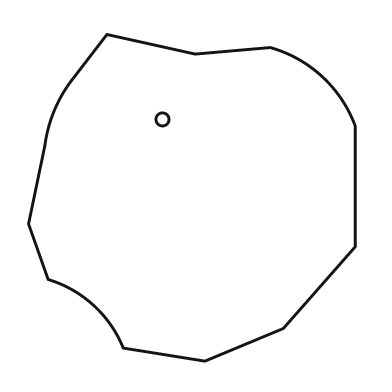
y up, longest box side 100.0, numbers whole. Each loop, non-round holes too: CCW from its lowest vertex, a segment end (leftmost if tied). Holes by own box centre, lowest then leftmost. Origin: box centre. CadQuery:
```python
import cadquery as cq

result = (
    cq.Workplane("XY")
    .moveTo(4.0, -50.0)
    .lineTo(28.0, -40.0)
    .lineTo(50.0, -15.0)
    .lineTo(50.0, 22.0)
    .threePointArc((40.0, 37.0), (24.0, 46.0))
    .lineTo(1.0, 44.0)
    .lineTo(-26.0, 50.0)
    .lineTo(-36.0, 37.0)
    .threePointArc((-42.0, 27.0), (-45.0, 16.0))
    .lineTo(-50.0, -8.0)
    .lineTo(-44.0, -25.0)
    .threePointArc((-30.0, -33.0), (-21.0, -46.0))
    .close()
    .moveTo(-9.0, 24.0)
    .circle(2.0)
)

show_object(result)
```